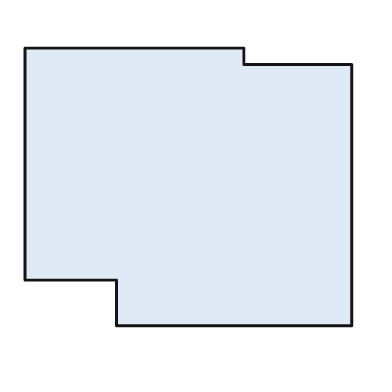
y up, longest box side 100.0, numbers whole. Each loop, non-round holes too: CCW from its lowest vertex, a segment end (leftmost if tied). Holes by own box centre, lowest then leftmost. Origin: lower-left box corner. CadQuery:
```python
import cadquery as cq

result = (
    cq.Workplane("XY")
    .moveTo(28.0, 0.0)
    .lineTo(100.0, 0.0)
    .lineTo(100.0, 80.0)
    .lineTo(67.0, 80.0)
    .lineTo(67.0, 85.0)
    .lineTo(0.0, 85.0)
    .lineTo(0.0, 14.0)
    .lineTo(28.0, 14.0)
    .close()
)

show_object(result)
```